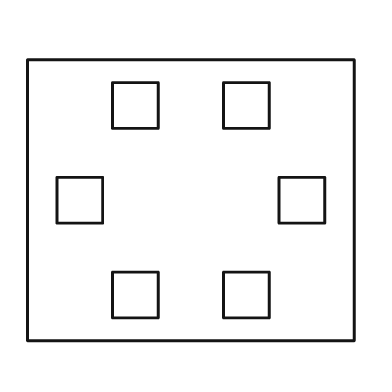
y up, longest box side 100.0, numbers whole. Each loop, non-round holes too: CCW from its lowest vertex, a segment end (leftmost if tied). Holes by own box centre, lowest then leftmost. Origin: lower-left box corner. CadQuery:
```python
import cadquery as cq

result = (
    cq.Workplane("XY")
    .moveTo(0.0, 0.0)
    .lineTo(100.0, 0.0)
    .lineTo(100.0, 86.0)
    .lineTo(0.0, 86.0)
    .close()
    .moveTo(26.0, 7.0)
    .lineTo(40.0, 7.0)
    .lineTo(40.0, 21.0)
    .lineTo(26.0, 21.0)
    .close()
    .moveTo(60.0, 7.0)
    .lineTo(74.0, 7.0)
    .lineTo(74.0, 21.0)
    .lineTo(60.0, 21.0)
    .close()
    .moveTo(9.0, 36.0)
    .lineTo(23.0, 36.0)
    .lineTo(23.0, 50.0)
    .lineTo(9.0, 50.0)
    .close()
    .moveTo(77.0, 36.0)
    .lineTo(91.0, 36.0)
    .lineTo(91.0, 50.0)
    .lineTo(77.0, 50.0)
    .close()
    .moveTo(26.0, 65.0)
    .lineTo(40.0, 65.0)
    .lineTo(40.0, 79.0)
    .lineTo(26.0, 79.0)
    .close()
    .moveTo(60.0, 65.0)
    .lineTo(74.0, 65.0)
    .lineTo(74.0, 79.0)
    .lineTo(60.0, 79.0)
    .close()
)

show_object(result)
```